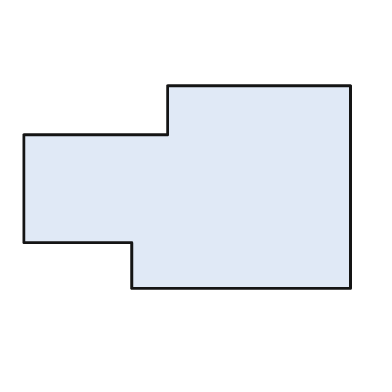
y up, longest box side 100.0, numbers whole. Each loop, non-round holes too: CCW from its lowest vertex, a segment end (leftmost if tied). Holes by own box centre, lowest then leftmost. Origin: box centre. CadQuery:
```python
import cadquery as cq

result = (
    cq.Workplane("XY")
    .moveTo(-17.0, -31.0)
    .lineTo(50.0, -31.0)
    .lineTo(50.0, 31.0)
    .lineTo(-6.0, 31.0)
    .lineTo(-6.0, 16.0)
    .lineTo(-50.0, 16.0)
    .lineTo(-50.0, -17.0)
    .lineTo(-17.0, -17.0)
    .close()
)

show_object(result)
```